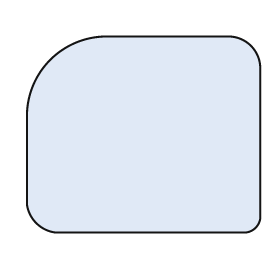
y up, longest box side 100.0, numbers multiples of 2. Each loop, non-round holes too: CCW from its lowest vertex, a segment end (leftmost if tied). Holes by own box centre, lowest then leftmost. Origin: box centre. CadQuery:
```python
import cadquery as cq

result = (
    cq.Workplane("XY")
    .moveTo(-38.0, -42.0)
    .lineTo(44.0, -42.0)
    .threePointArc((48.0, -40.0), (50.0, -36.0))
    .lineTo(50.0, 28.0)
    .threePointArc((46.0, 38.0), (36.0, 42.0))
    .lineTo(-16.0, 42.0)
    .threePointArc((-40.0, 32.0), (-50.0, 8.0))
    .lineTo(-50.0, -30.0)
    .threePointArc((-46.0, -38.0), (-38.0, -42.0))
    .close()
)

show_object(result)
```